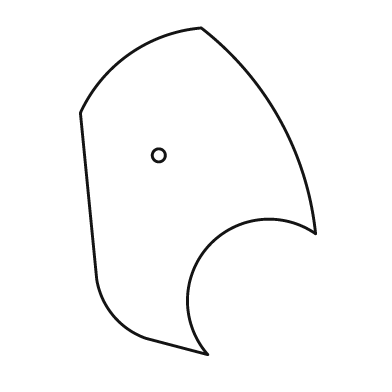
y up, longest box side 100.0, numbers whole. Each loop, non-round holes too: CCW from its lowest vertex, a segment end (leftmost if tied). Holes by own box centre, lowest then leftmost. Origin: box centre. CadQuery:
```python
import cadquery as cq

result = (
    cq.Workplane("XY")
    .moveTo(3.0, -50.0)
    .threePointArc((3.0, -17.0), (36.0, -13.0))
    .threePointArc((25.0, 22.0), (1.0, 50.0))
    .threePointArc((-21.0, 42.0), (-36.0, 24.0))
    .lineTo(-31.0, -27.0)
    .threePointArc((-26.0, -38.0), (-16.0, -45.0))
    .close()
    .moveTo(-12.0, 11.0)
    .circle(2.0)
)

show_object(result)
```